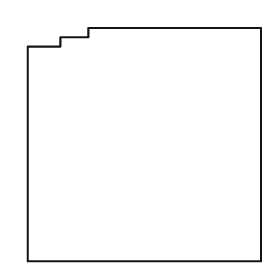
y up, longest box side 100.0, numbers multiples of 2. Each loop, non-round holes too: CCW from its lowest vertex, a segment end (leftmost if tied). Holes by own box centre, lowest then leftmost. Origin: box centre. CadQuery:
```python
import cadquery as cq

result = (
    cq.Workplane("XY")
    .moveTo(-50.0, -50.0)
    .lineTo(50.0, -50.0)
    .lineTo(50.0, 50.0)
    .lineTo(-24.0, 50.0)
    .lineTo(-24.0, 46.0)
    .lineTo(-36.0, 46.0)
    .lineTo(-36.0, 42.0)
    .lineTo(-50.0, 42.0)
    .close()
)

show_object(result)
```